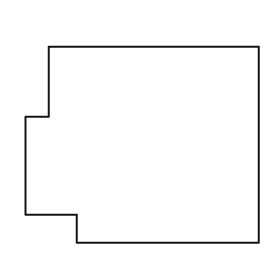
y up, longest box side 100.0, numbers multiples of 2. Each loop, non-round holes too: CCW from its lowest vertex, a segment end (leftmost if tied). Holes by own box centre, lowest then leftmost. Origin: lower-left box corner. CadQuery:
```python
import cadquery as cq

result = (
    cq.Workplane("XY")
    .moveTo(22.0, 0.0)
    .lineTo(100.0, 0.0)
    .lineTo(100.0, 84.0)
    .lineTo(10.0, 84.0)
    .lineTo(10.0, 54.0)
    .lineTo(0.0, 54.0)
    .lineTo(0.0, 12.0)
    .lineTo(22.0, 12.0)
    .close()
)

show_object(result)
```